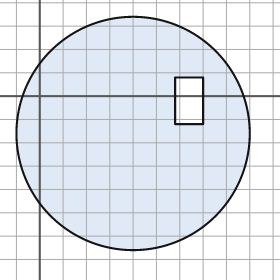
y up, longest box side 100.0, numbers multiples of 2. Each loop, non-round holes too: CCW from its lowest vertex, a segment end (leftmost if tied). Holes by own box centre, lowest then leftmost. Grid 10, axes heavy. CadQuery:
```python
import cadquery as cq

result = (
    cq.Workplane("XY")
    .moveTo(40.0, -16.0)
    .circle(50.0)
    .moveTo(58.0, -12.0)
    .lineTo(70.0, -12.0)
    .lineTo(70.0, 8.0)
    .lineTo(58.0, 8.0)
    .close()
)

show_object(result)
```